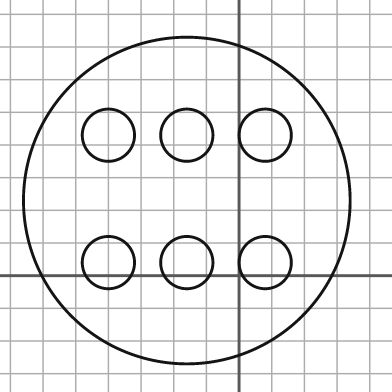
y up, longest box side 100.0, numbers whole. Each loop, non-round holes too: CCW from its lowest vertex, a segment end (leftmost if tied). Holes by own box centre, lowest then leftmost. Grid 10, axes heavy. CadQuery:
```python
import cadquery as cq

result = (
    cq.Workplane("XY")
    .moveTo(-16.0, 23.0)
    .circle(50.0)
    .moveTo(-40.0, 4.0)
    .circle(8.0)
    .moveTo(-16.0, 4.0)
    .circle(8.0)
    .moveTo(8.0, 4.0)
    .circle(8.0)
    .moveTo(-40.0, 43.0)
    .circle(8.0)
    .moveTo(-16.0, 43.0)
    .circle(8.0)
    .moveTo(8.0, 43.0)
    .circle(8.0)
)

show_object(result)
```